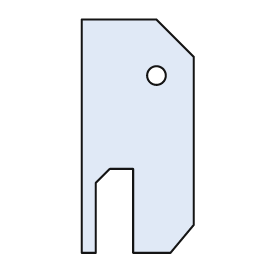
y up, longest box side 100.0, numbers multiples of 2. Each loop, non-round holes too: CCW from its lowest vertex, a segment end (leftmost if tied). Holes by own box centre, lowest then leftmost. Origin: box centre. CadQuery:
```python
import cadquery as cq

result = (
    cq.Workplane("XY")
    .moveTo(-24.0, -50.0)
    .lineTo(-18.0, -50.0)
    .lineTo(-18.0, -20.0)
    .lineTo(-12.0, -14.0)
    .lineTo(-2.0, -14.0)
    .lineTo(-2.0, -50.0)
    .lineTo(14.0, -50.0)
    .lineTo(24.0, -38.0)
    .lineTo(24.0, 34.0)
    .lineTo(8.0, 50.0)
    .lineTo(-24.0, 50.0)
    .close()
    .moveTo(8.0, 26.0)
    .circle(4.0)
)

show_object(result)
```